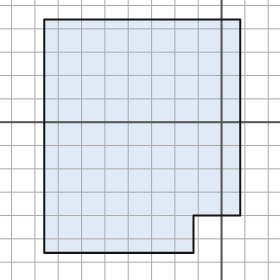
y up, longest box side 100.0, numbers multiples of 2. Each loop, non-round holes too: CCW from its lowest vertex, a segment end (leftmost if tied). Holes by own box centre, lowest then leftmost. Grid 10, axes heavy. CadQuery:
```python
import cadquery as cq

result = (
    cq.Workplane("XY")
    .moveTo(-76.0, -56.0)
    .lineTo(-12.0, -56.0)
    .lineTo(-12.0, -40.0)
    .lineTo(8.0, -40.0)
    .lineTo(8.0, 44.0)
    .lineTo(-76.0, 44.0)
    .close()
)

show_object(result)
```